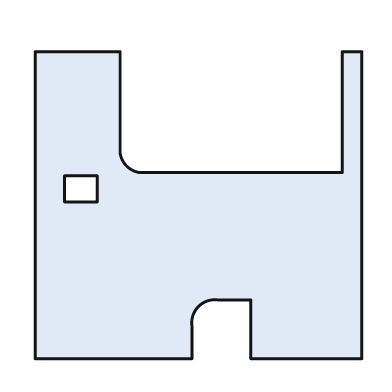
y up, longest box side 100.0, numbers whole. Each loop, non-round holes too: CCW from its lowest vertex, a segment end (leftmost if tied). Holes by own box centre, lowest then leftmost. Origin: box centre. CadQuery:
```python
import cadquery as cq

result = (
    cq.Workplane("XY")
    .moveTo(-50.0, -47.0)
    .lineTo(-2.0, -47.0)
    .lineTo(-2.0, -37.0)
    .threePointArc((0.0, -31.0), (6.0, -29.0))
    .lineTo(16.0, -29.0)
    .lineTo(16.0, -47.0)
    .lineTo(50.0, -47.0)
    .lineTo(50.0, 47.0)
    .lineTo(44.0, 47.0)
    .lineTo(44.0, 10.0)
    .lineTo(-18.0, 10.0)
    .threePointArc((-22.0, 12.0), (-24.0, 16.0))
    .lineTo(-24.0, 47.0)
    .lineTo(-50.0, 47.0)
    .close()
    .moveTo(-41.0, 1.0)
    .lineTo(-31.0, 1.0)
    .lineTo(-31.0, 9.0)
    .lineTo(-41.0, 9.0)
    .close()
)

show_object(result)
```